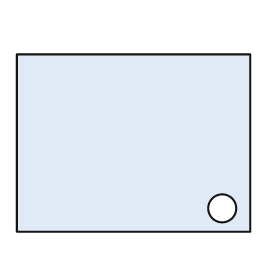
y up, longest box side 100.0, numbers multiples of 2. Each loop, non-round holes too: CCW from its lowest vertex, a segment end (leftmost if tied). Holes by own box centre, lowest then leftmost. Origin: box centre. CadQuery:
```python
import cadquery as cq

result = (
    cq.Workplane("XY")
    .moveTo(-50.0, -38.0)
    .lineTo(50.0, -38.0)
    .lineTo(50.0, 38.0)
    .lineTo(-50.0, 38.0)
    .close()
    .moveTo(38.0, -28.0)
    .circle(6.0)
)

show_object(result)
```